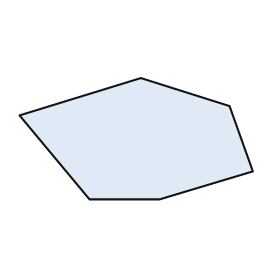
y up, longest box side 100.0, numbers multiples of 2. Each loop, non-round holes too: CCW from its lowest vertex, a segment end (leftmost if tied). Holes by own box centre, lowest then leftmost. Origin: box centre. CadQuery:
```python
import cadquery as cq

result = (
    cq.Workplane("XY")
    .moveTo(-20.0, -26.0)
    .lineTo(10.0, -26.0)
    .lineTo(50.0, -14.0)
    .lineTo(40.0, 14.0)
    .lineTo(2.0, 26.0)
    .lineTo(-50.0, 10.0)
    .close()
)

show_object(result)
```